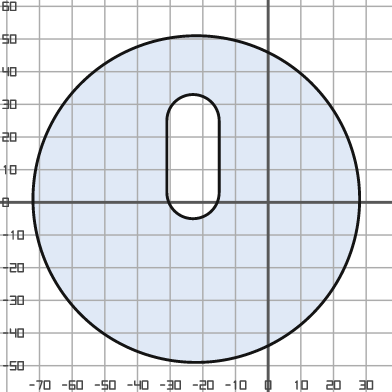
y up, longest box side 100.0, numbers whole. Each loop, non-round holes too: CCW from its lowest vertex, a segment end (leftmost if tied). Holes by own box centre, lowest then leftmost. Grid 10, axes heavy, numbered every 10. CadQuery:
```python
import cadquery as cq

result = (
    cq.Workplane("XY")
    .moveTo(-22.0, 1.0)
    .circle(50.0)
    .moveTo(-31.0, 3.0)
    .threePointArc((-23.0, -5.0), (-15.0, 3.0))
    .lineTo(-15.0, 25.0)
    .threePointArc((-23.0, 33.0), (-31.0, 25.0))
    .close()
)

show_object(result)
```